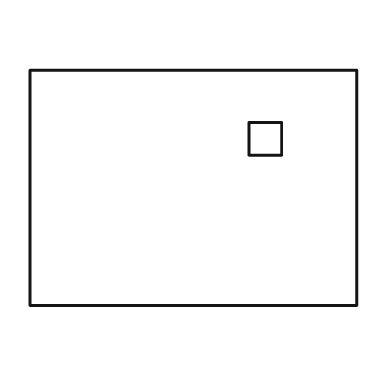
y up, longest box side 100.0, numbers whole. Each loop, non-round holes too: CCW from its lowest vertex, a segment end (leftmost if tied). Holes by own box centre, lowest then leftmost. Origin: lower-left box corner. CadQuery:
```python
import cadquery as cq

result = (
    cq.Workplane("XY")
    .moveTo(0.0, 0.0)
    .lineTo(100.0, 0.0)
    .lineTo(100.0, 72.0)
    .lineTo(0.0, 72.0)
    .close()
    .moveTo(67.0, 46.0)
    .lineTo(77.0, 46.0)
    .lineTo(77.0, 56.0)
    .lineTo(67.0, 56.0)
    .close()
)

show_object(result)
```